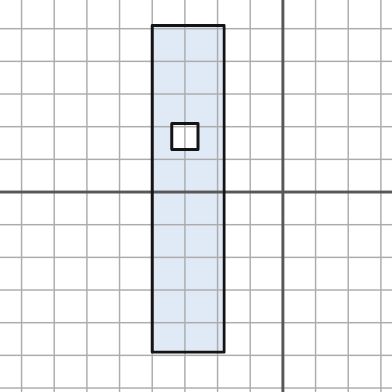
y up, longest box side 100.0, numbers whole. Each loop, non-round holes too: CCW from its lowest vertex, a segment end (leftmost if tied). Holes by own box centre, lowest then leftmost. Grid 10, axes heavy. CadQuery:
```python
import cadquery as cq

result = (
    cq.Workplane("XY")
    .moveTo(-40.0, -49.0)
    .lineTo(-18.0, -49.0)
    .lineTo(-18.0, 51.0)
    .lineTo(-40.0, 51.0)
    .close()
    .moveTo(-34.0, 13.0)
    .lineTo(-26.0, 13.0)
    .lineTo(-26.0, 21.0)
    .lineTo(-34.0, 21.0)
    .close()
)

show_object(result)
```